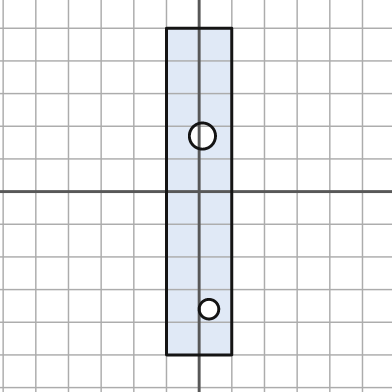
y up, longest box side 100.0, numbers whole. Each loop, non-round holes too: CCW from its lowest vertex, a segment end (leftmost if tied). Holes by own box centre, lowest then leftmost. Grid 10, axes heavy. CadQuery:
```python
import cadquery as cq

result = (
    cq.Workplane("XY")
    .moveTo(-10.0, -50.0)
    .lineTo(10.0, -50.0)
    .lineTo(10.0, 50.0)
    .lineTo(-10.0, 50.0)
    .close()
    .moveTo(3.0, -36.0)
    .circle(3.0)
    .moveTo(1.0, 17.0)
    .circle(4.0)
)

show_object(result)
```